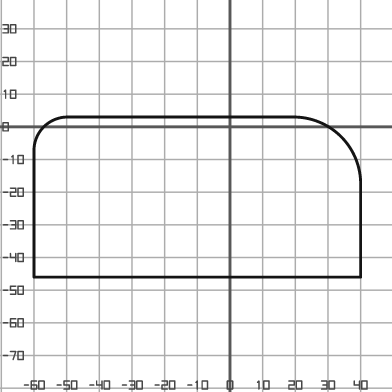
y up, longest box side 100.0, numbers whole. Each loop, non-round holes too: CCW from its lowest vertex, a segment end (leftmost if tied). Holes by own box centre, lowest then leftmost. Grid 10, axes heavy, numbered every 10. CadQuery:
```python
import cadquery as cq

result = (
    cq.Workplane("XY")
    .moveTo(-60.0, -46.0)
    .lineTo(40.0, -46.0)
    .lineTo(40.0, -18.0)
    .threePointArc((34.0, -3.0), (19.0, 3.0))
    .lineTo(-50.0, 3.0)
    .threePointArc((-57.0, 0.0), (-60.0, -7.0))
    .close()
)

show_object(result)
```